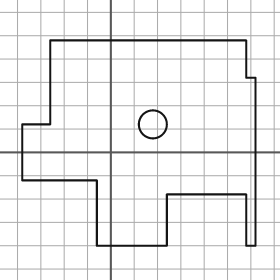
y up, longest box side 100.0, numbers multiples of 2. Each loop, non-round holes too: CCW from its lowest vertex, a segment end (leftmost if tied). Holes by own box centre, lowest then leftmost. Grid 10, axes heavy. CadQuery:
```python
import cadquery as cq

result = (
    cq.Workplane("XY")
    .moveTo(-6.0, -40.0)
    .lineTo(24.0, -40.0)
    .lineTo(24.0, -18.0)
    .lineTo(58.0, -18.0)
    .lineTo(58.0, -40.0)
    .lineTo(62.0, -40.0)
    .lineTo(62.0, 32.0)
    .lineTo(58.0, 32.0)
    .lineTo(58.0, 48.0)
    .lineTo(-26.0, 48.0)
    .lineTo(-26.0, 12.0)
    .lineTo(-38.0, 12.0)
    .lineTo(-38.0, -12.0)
    .lineTo(-6.0, -12.0)
    .close()
    .moveTo(18.0, 12.0)
    .circle(6.0)
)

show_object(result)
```